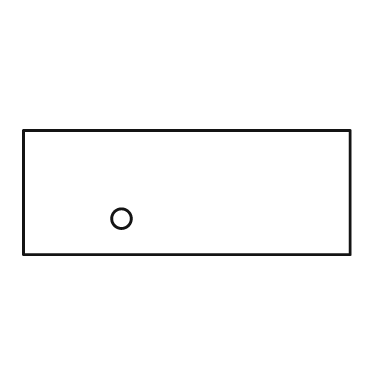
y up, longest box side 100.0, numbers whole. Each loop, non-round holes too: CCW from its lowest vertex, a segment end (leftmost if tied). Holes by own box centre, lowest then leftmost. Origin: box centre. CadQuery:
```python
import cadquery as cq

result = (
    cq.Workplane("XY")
    .moveTo(-50.0, -19.0)
    .lineTo(50.0, -19.0)
    .lineTo(50.0, 19.0)
    .lineTo(-50.0, 19.0)
    .close()
    .moveTo(-20.0, -8.0)
    .circle(3.0)
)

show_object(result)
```